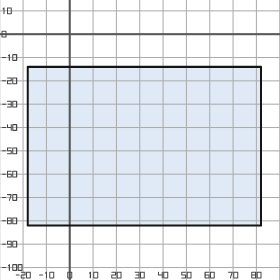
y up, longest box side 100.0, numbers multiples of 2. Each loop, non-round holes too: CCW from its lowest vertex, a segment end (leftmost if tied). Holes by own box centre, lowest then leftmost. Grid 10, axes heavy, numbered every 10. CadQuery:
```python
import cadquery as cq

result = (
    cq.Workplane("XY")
    .moveTo(-18.0, -82.0)
    .lineTo(82.0, -82.0)
    .lineTo(82.0, -14.0)
    .lineTo(-18.0, -14.0)
    .close()
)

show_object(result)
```